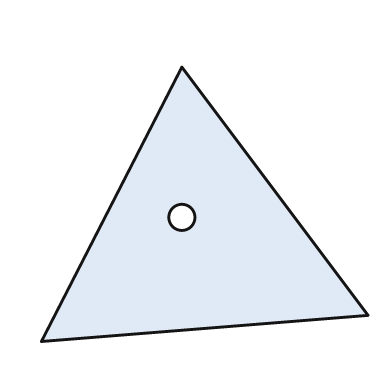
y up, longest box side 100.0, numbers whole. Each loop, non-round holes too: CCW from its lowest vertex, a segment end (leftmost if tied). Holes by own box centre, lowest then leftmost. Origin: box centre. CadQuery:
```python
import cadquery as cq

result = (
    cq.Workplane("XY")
    .moveTo(-50.0, -42.0)
    .lineTo(50.0, -34.0)
    .lineTo(-7.0, 42.0)
    .close()
    .moveTo(-7.0, -4.0)
    .circle(4.0)
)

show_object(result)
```